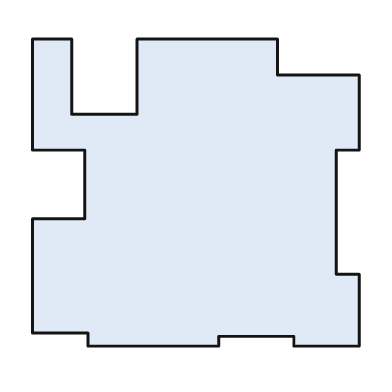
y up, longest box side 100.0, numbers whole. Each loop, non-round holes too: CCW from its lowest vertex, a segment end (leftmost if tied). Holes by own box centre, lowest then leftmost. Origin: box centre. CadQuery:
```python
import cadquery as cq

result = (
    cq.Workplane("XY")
    .moveTo(-33.0, -47.0)
    .lineTo(7.0, -47.0)
    .lineTo(7.0, -44.0)
    .lineTo(30.0, -44.0)
    .lineTo(30.0, -47.0)
    .lineTo(50.0, -47.0)
    .lineTo(50.0, -25.0)
    .lineTo(43.0, -25.0)
    .lineTo(43.0, 13.0)
    .lineTo(50.0, 13.0)
    .lineTo(50.0, 36.0)
    .lineTo(25.0, 36.0)
    .lineTo(25.0, 47.0)
    .lineTo(-18.0, 47.0)
    .lineTo(-18.0, 24.0)
    .lineTo(-38.0, 24.0)
    .lineTo(-38.0, 47.0)
    .lineTo(-50.0, 47.0)
    .lineTo(-50.0, 13.0)
    .lineTo(-34.0, 13.0)
    .lineTo(-34.0, -8.0)
    .lineTo(-50.0, -8.0)
    .lineTo(-50.0, -43.0)
    .lineTo(-33.0, -43.0)
    .close()
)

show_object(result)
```